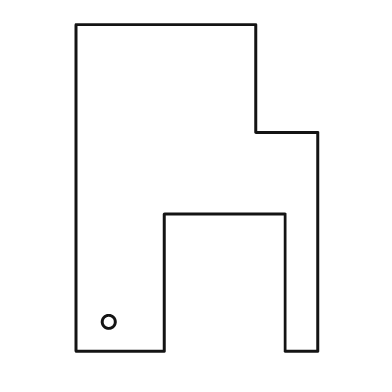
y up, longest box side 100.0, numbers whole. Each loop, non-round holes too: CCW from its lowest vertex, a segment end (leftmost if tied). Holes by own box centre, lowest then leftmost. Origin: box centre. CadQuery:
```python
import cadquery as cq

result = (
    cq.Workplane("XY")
    .moveTo(-37.0, -50.0)
    .lineTo(-10.0, -50.0)
    .lineTo(-10.0, -8.0)
    .lineTo(27.0, -8.0)
    .lineTo(27.0, -50.0)
    .lineTo(37.0, -50.0)
    .lineTo(37.0, 17.0)
    .lineTo(18.0, 17.0)
    .lineTo(18.0, 50.0)
    .lineTo(-37.0, 50.0)
    .close()
    .moveTo(-27.0, -41.0)
    .circle(2.0)
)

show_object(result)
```